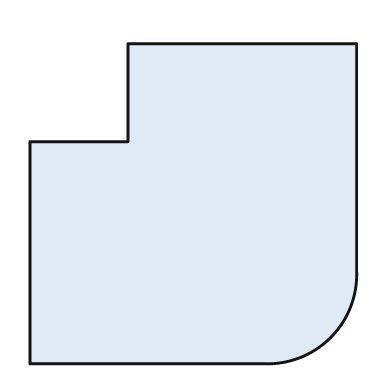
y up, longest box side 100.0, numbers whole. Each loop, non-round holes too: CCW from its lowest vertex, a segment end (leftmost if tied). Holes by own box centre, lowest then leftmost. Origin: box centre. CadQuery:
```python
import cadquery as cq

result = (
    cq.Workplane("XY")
    .moveTo(-50.0, -49.0)
    .lineTo(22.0, -49.0)
    .threePointArc((42.0, -41.0), (50.0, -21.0))
    .lineTo(50.0, 49.0)
    .lineTo(-20.0, 49.0)
    .lineTo(-20.0, 19.0)
    .lineTo(-50.0, 19.0)
    .close()
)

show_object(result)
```